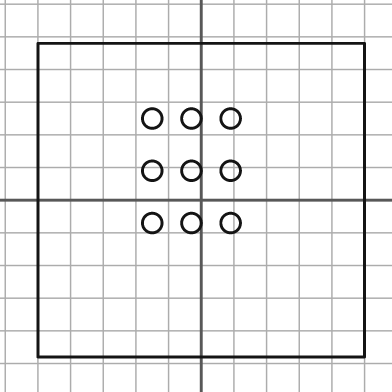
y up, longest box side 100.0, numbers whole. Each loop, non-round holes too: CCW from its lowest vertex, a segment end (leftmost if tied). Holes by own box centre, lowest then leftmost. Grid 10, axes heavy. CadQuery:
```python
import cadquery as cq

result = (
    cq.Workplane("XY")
    .moveTo(-50.0, -48.0)
    .lineTo(50.0, -48.0)
    .lineTo(50.0, 48.0)
    .lineTo(-50.0, 48.0)
    .close()
    .moveTo(-15.0, -7.0)
    .circle(3.0)
    .moveTo(-3.0, -7.0)
    .circle(3.0)
    .moveTo(9.0, -7.0)
    .circle(3.0)
    .moveTo(-15.0, 9.0)
    .circle(3.0)
    .moveTo(-3.0, 9.0)
    .circle(3.0)
    .moveTo(9.0, 9.0)
    .circle(3.0)
    .moveTo(-15.0, 25.0)
    .circle(3.0)
    .moveTo(-3.0, 25.0)
    .circle(3.0)
    .moveTo(9.0, 25.0)
    .circle(3.0)
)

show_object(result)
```